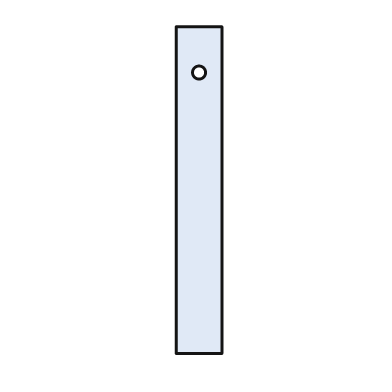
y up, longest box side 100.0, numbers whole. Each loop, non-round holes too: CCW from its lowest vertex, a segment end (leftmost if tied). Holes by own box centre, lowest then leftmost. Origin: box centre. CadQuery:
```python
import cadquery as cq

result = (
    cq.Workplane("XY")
    .moveTo(-7.0, -50.0)
    .lineTo(7.0, -50.0)
    .lineTo(7.0, 50.0)
    .lineTo(-7.0, 50.0)
    .close()
    .moveTo(0.0, 36.0)
    .circle(2.0)
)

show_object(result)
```